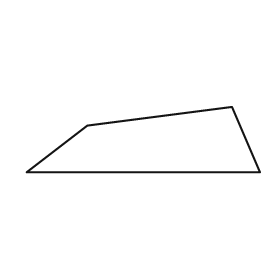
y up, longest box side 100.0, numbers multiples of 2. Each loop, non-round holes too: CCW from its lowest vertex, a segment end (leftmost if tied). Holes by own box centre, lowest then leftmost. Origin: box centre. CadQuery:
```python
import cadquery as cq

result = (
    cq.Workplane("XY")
    .moveTo(-50.0, -14.0)
    .lineTo(50.0, -14.0)
    .lineTo(38.0, 14.0)
    .lineTo(-24.0, 6.0)
    .close()
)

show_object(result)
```